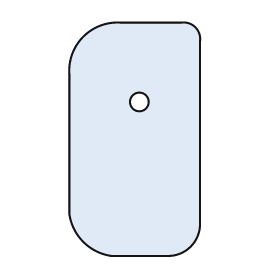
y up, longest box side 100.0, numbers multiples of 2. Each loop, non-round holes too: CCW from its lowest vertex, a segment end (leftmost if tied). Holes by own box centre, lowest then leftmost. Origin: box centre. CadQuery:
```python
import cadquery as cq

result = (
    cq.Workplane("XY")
    .moveTo(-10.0, -50.0)
    .lineTo(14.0, -50.0)
    .threePointArc((24.0, -46.0), (28.0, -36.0))
    .lineTo(28.0, 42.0)
    .threePointArc((26.0, 48.0), (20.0, 50.0))
    .lineTo(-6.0, 50.0)
    .threePointArc((-22.0, 44.0), (-28.0, 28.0))
    .lineTo(-28.0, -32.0)
    .threePointArc((-22.0, -44.0), (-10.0, -50.0))
    .close()
    .moveTo(2.0, 16.0)
    .circle(4.0)
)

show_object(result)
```